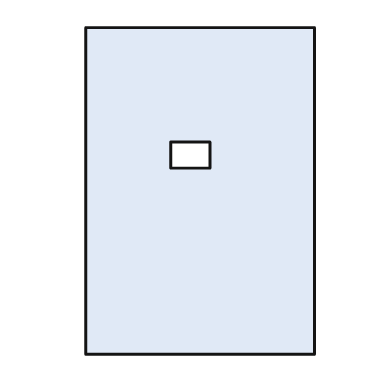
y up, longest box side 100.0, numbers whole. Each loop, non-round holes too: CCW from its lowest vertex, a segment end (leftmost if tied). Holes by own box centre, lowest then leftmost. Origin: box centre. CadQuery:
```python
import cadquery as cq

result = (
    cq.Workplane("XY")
    .moveTo(-35.0, -50.0)
    .lineTo(35.0, -50.0)
    .lineTo(35.0, 50.0)
    .lineTo(-35.0, 50.0)
    .close()
    .moveTo(-9.0, 7.0)
    .lineTo(3.0, 7.0)
    .lineTo(3.0, 15.0)
    .lineTo(-9.0, 15.0)
    .close()
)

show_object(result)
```